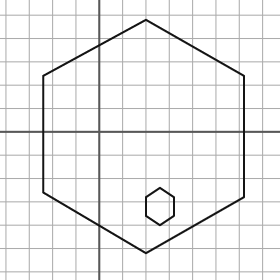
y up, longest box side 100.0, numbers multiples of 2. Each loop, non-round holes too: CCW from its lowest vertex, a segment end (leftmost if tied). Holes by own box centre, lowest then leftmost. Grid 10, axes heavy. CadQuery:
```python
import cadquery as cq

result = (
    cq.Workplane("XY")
    .moveTo(20.0, -52.0)
    .lineTo(62.0, -28.0)
    .lineTo(62.0, 24.0)
    .lineTo(20.0, 48.0)
    .lineTo(-24.0, 24.0)
    .lineTo(-24.0, -26.0)
    .close()
    .moveTo(26.0, -40.0)
    .lineTo(32.0, -36.0)
    .lineTo(32.0, -28.0)
    .lineTo(26.0, -24.0)
    .lineTo(20.0, -28.0)
    .lineTo(20.0, -36.0)
    .close()
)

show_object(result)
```